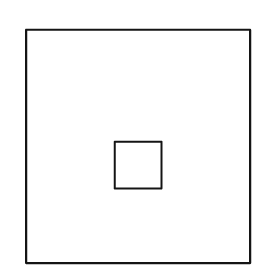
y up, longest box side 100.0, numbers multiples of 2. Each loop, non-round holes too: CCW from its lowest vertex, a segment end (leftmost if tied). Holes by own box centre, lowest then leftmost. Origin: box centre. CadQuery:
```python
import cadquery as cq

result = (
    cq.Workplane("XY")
    .moveTo(-48.0, -50.0)
    .lineTo(48.0, -50.0)
    .lineTo(48.0, 50.0)
    .lineTo(-48.0, 50.0)
    .close()
    .moveTo(-10.0, -18.0)
    .lineTo(10.0, -18.0)
    .lineTo(10.0, 2.0)
    .lineTo(-10.0, 2.0)
    .close()
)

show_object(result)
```